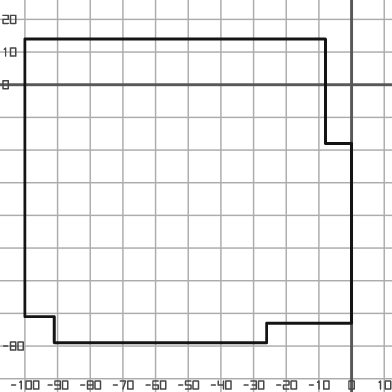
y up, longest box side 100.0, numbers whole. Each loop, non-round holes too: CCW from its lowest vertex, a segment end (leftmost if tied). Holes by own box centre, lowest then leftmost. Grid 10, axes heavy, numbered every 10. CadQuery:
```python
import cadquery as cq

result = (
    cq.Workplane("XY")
    .moveTo(-91.0, -79.0)
    .lineTo(-26.0, -79.0)
    .lineTo(-26.0, -73.0)
    .lineTo(0.0, -73.0)
    .lineTo(0.0, -18.0)
    .lineTo(-8.0, -18.0)
    .lineTo(-8.0, 14.0)
    .lineTo(-100.0, 14.0)
    .lineTo(-100.0, -71.0)
    .lineTo(-91.0, -71.0)
    .close()
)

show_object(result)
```